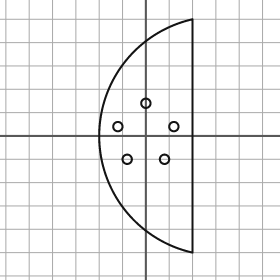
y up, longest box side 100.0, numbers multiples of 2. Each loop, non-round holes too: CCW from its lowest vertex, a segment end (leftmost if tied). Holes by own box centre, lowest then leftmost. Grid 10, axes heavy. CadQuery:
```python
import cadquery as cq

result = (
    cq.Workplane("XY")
    .moveTo(20.0, -50.0)
    .lineTo(20.0, 50.0)
    .threePointArc((-20.0, 0.0), (20.0, -50.0))
    .close()
    .moveTo(-8.0, -10.0)
    .circle(2.0)
    .moveTo(8.0, -10.0)
    .circle(2.0)
    .moveTo(-12.0, 4.0)
    .circle(2.0)
    .moveTo(12.0, 4.0)
    .circle(2.0)
    .moveTo(0.0, 14.0)
    .circle(2.0)
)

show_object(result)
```